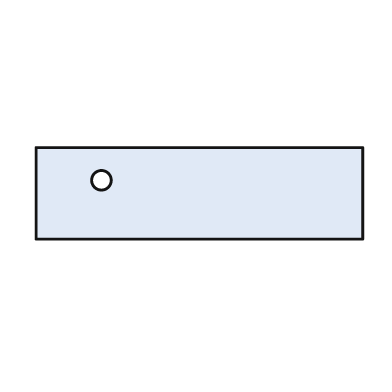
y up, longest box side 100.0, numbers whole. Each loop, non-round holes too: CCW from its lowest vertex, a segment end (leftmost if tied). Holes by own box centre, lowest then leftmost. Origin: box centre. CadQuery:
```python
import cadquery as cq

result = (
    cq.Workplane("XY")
    .moveTo(-50.0, -14.0)
    .lineTo(50.0, -14.0)
    .lineTo(50.0, 14.0)
    .lineTo(-50.0, 14.0)
    .close()
    .moveTo(-30.0, 4.0)
    .circle(3.0)
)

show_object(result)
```